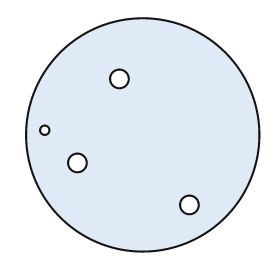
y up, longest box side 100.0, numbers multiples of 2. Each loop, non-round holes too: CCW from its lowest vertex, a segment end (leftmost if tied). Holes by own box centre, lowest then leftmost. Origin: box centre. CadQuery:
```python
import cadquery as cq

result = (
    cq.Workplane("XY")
    .moveTo(0.0, 0.0)
    .circle(50.0)
    .moveTo(20.0, -30.0)
    .circle(4.0)
    .moveTo(-28.0, -12.0)
    .circle(4.0)
    .moveTo(-42.0, 2.0)
    .circle(2.0)
    .moveTo(-10.0, 24.0)
    .circle(4.0)
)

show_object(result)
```